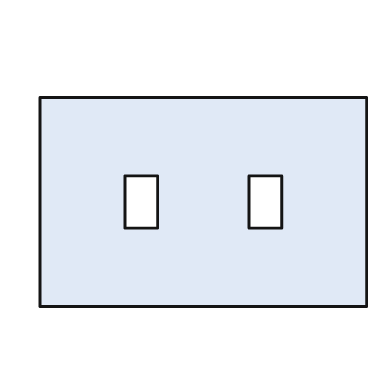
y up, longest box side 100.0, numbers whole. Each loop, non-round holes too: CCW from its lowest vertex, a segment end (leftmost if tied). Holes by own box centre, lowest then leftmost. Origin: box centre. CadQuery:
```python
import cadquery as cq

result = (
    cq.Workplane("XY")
    .moveTo(-50.0, -32.0)
    .lineTo(50.0, -32.0)
    .lineTo(50.0, 32.0)
    .lineTo(-50.0, 32.0)
    .close()
    .moveTo(-24.0, -8.0)
    .lineTo(-14.0, -8.0)
    .lineTo(-14.0, 8.0)
    .lineTo(-24.0, 8.0)
    .close()
    .moveTo(14.0, -8.0)
    .lineTo(24.0, -8.0)
    .lineTo(24.0, 8.0)
    .lineTo(14.0, 8.0)
    .close()
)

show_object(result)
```